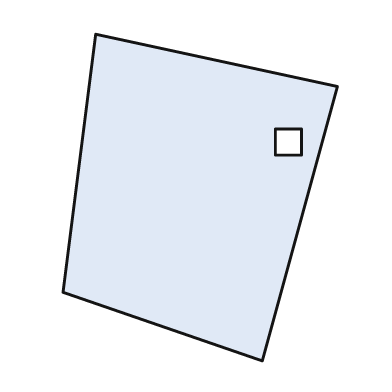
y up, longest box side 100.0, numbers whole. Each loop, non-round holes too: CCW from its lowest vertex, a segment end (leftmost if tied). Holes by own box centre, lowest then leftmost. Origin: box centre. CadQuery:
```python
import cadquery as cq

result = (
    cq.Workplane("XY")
    .moveTo(19.0, -50.0)
    .lineTo(42.0, 34.0)
    .lineTo(-32.0, 50.0)
    .lineTo(-42.0, -29.0)
    .close()
    .moveTo(23.0, 13.0)
    .lineTo(31.0, 13.0)
    .lineTo(31.0, 21.0)
    .lineTo(23.0, 21.0)
    .close()
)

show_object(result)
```